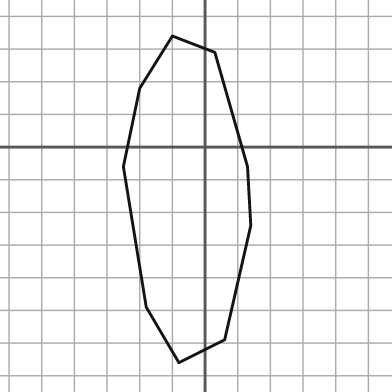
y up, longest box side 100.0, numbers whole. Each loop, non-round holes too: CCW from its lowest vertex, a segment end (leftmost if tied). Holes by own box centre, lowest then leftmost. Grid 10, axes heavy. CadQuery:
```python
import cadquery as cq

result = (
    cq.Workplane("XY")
    .moveTo(-8.0, -66.0)
    .lineTo(6.0, -59.0)
    .lineTo(14.0, -24.0)
    .lineTo(13.0, -6.0)
    .lineTo(3.0, 29.0)
    .lineTo(-10.0, 34.0)
    .lineTo(-20.0, 18.0)
    .lineTo(-25.0, -6.0)
    .lineTo(-18.0, -49.0)
    .close()
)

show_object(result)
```